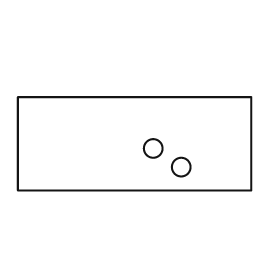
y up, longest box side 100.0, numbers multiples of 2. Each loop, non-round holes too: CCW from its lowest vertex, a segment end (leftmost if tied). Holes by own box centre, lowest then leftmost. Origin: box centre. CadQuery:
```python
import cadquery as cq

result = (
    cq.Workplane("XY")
    .moveTo(-50.0, -20.0)
    .lineTo(50.0, -20.0)
    .lineTo(50.0, 20.0)
    .lineTo(-50.0, 20.0)
    .close()
    .moveTo(20.0, -10.0)
    .circle(4.0)
    .moveTo(8.0, -2.0)
    .circle(4.0)
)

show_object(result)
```